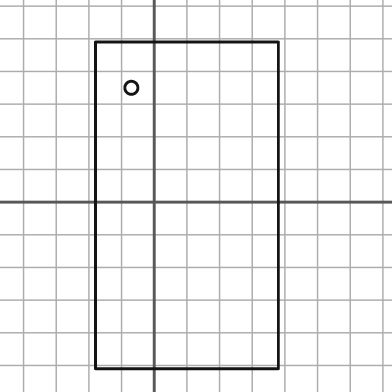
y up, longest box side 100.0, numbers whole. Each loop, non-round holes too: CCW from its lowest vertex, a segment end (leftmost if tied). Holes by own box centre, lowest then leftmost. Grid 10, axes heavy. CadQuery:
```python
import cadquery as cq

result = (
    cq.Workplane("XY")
    .moveTo(-18.0, -51.0)
    .lineTo(38.0, -51.0)
    .lineTo(38.0, 49.0)
    .lineTo(-18.0, 49.0)
    .close()
    .moveTo(-7.0, 35.0)
    .circle(2.0)
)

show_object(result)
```